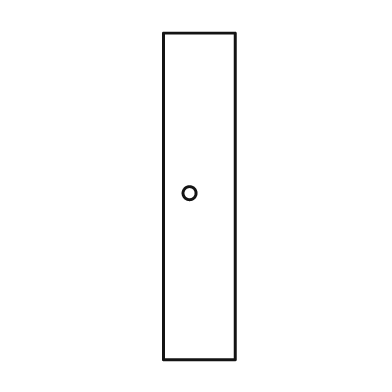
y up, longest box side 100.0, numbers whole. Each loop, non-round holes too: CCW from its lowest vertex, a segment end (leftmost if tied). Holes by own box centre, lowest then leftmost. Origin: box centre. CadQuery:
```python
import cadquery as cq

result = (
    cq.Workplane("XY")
    .moveTo(-11.0, -50.0)
    .lineTo(11.0, -50.0)
    .lineTo(11.0, 50.0)
    .lineTo(-11.0, 50.0)
    .close()
    .moveTo(-3.0, 1.0)
    .circle(2.0)
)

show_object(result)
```